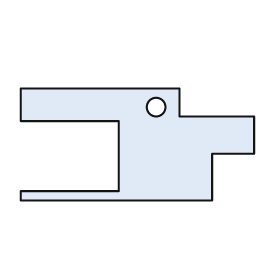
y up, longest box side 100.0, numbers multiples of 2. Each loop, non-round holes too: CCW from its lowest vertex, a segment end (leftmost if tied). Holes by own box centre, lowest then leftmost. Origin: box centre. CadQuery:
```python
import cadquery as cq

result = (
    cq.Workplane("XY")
    .moveTo(-50.0, -24.0)
    .lineTo(32.0, -24.0)
    .lineTo(32.0, -4.0)
    .lineTo(50.0, -4.0)
    .lineTo(50.0, 12.0)
    .lineTo(18.0, 12.0)
    .lineTo(18.0, 24.0)
    .lineTo(-50.0, 24.0)
    .lineTo(-50.0, 10.0)
    .lineTo(-8.0, 10.0)
    .lineTo(-8.0, -20.0)
    .lineTo(-50.0, -20.0)
    .close()
    .moveTo(8.0, 16.0)
    .circle(4.0)
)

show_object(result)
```